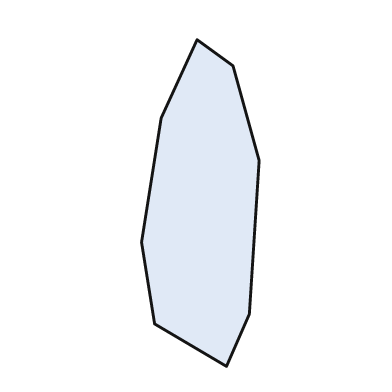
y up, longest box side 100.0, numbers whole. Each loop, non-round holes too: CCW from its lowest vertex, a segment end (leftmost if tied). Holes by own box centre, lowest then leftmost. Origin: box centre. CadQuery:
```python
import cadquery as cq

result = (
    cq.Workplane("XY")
    .moveTo(8.0, -50.0)
    .lineTo(15.0, -34.0)
    .lineTo(18.0, 13.0)
    .lineTo(10.0, 42.0)
    .lineTo(-1.0, 50.0)
    .lineTo(-12.0, 26.0)
    .lineTo(-18.0, -12.0)
    .lineTo(-14.0, -37.0)
    .close()
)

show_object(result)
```